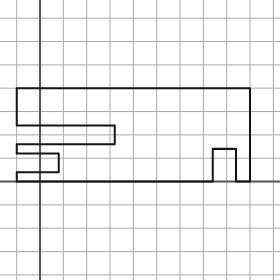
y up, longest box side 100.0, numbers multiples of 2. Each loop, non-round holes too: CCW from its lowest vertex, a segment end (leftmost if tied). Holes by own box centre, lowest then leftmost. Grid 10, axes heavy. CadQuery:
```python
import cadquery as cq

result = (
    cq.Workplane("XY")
    .moveTo(-10.0, 0.0)
    .lineTo(74.0, 0.0)
    .lineTo(74.0, 14.0)
    .lineTo(84.0, 14.0)
    .lineTo(84.0, 0.0)
    .lineTo(90.0, 0.0)
    .lineTo(90.0, 40.0)
    .lineTo(-10.0, 40.0)
    .lineTo(-10.0, 24.0)
    .lineTo(32.0, 24.0)
    .lineTo(32.0, 16.0)
    .lineTo(-10.0, 16.0)
    .lineTo(-10.0, 12.0)
    .lineTo(8.0, 12.0)
    .lineTo(8.0, 4.0)
    .lineTo(-10.0, 4.0)
    .close()
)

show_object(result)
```